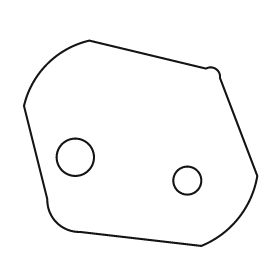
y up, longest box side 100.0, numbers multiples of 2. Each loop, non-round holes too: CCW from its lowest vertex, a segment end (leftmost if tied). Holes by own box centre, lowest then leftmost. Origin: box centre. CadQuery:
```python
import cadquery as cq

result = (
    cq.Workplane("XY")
    .moveTo(26.0, -44.0)
    .threePointArc((42.0, -32.0), (50.0, -14.0))
    .lineTo(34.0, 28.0)
    .threePointArc((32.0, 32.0), (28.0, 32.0))
    .lineTo(-22.0, 44.0)
    .threePointArc((-40.0, 34.0), (-50.0, 16.0))
    .lineTo(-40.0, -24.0)
    .threePointArc((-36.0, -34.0), (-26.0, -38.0))
    .close()
    .moveTo(20.0, -16.0)
    .circle(6.0)
    .moveTo(-28.0, -6.0)
    .circle(8.0)
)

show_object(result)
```